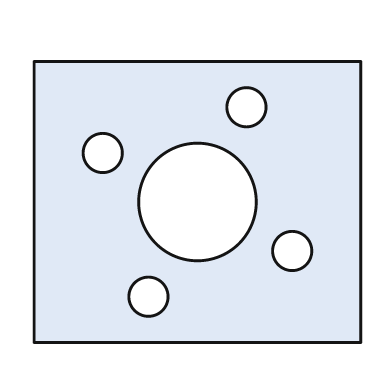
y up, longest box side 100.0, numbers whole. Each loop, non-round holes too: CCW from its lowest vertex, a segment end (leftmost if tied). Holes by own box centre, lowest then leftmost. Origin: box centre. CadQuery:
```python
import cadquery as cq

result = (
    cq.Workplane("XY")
    .moveTo(-50.0, -43.0)
    .lineTo(50.0, -43.0)
    .lineTo(50.0, 43.0)
    .lineTo(-50.0, 43.0)
    .close()
    .moveTo(-15.0, -29.0)
    .circle(6.0)
    .moveTo(29.0, -15.0)
    .circle(6.0)
    .moveTo(0.0, 0.0)
    .circle(18.0)
    .moveTo(-29.0, 15.0)
    .circle(6.0)
    .moveTo(15.0, 29.0)
    .circle(6.0)
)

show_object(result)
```